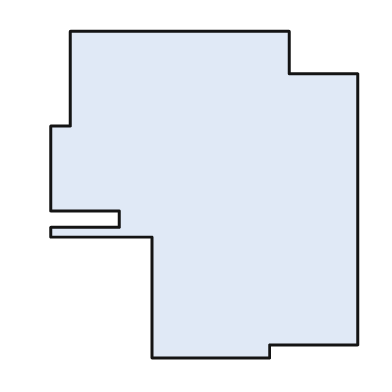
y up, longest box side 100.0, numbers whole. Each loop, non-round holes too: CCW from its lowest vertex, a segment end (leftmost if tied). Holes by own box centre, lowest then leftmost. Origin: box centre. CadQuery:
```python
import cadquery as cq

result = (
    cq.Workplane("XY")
    .moveTo(-16.0, -50.0)
    .lineTo(20.0, -50.0)
    .lineTo(20.0, -46.0)
    .lineTo(47.0, -46.0)
    .lineTo(47.0, 37.0)
    .lineTo(26.0, 37.0)
    .lineTo(26.0, 50.0)
    .lineTo(-41.0, 50.0)
    .lineTo(-41.0, 21.0)
    .lineTo(-47.0, 21.0)
    .lineTo(-47.0, -5.0)
    .lineTo(-26.0, -5.0)
    .lineTo(-26.0, -10.0)
    .lineTo(-47.0, -10.0)
    .lineTo(-47.0, -13.0)
    .lineTo(-16.0, -13.0)
    .close()
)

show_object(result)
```